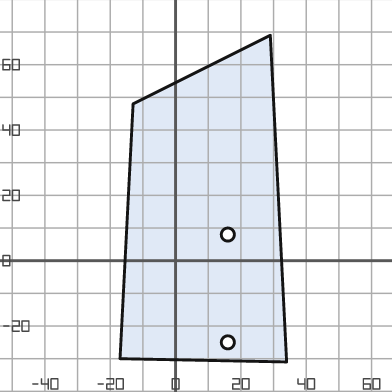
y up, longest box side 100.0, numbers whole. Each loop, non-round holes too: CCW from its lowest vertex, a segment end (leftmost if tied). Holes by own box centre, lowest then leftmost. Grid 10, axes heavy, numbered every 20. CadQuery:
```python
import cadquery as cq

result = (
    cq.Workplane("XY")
    .moveTo(34.0, -31.0)
    .lineTo(29.0, 69.0)
    .lineTo(-13.0, 48.0)
    .lineTo(-17.0, -30.0)
    .close()
    .moveTo(16.0, -25.0)
    .circle(2.0)
    .moveTo(16.0, 8.0)
    .circle(2.0)
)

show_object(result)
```